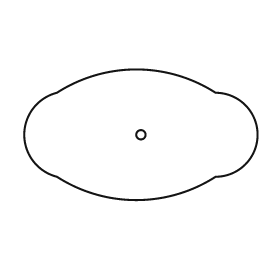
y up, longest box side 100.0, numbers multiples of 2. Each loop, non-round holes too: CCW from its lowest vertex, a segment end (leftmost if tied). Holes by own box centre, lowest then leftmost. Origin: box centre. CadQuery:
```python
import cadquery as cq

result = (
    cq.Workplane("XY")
    .moveTo(-36.0, -18.0)
    .threePointArc((-2.0, -28.0), (32.0, -18.0))
    .threePointArc((50.0, 0.0), (32.0, 18.0))
    .threePointArc((-2.0, 28.0), (-36.0, 18.0))
    .threePointArc((-50.0, 0.0), (-36.0, -18.0))
    .close()
    .moveTo(0.0, 0.0)
    .circle(2.0)
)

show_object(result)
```